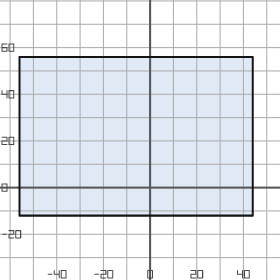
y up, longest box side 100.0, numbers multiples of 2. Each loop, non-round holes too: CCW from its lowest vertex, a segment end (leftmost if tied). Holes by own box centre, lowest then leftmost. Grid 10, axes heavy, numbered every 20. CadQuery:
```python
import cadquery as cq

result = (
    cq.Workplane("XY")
    .moveTo(-56.0, -12.0)
    .lineTo(44.0, -12.0)
    .lineTo(44.0, 56.0)
    .lineTo(-56.0, 56.0)
    .close()
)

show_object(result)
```